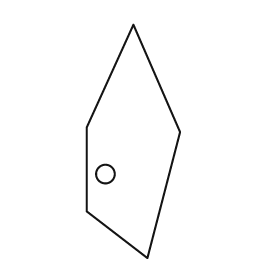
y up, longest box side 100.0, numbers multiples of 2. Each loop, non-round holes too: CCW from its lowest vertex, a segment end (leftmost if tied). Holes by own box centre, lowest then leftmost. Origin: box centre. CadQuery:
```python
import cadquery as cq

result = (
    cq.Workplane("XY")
    .moveTo(6.0, -50.0)
    .lineTo(20.0, 4.0)
    .lineTo(0.0, 50.0)
    .lineTo(-20.0, 6.0)
    .lineTo(-20.0, -30.0)
    .close()
    .moveTo(-12.0, -14.0)
    .circle(4.0)
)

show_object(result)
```